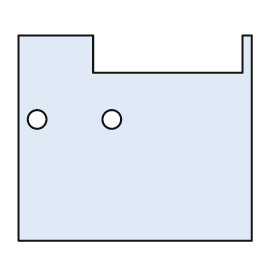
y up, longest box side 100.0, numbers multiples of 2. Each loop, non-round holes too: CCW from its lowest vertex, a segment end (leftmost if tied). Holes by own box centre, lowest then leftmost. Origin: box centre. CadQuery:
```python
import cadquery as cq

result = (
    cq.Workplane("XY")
    .moveTo(-50.0, -44.0)
    .lineTo(50.0, -44.0)
    .lineTo(50.0, 44.0)
    .lineTo(46.0, 44.0)
    .lineTo(46.0, 28.0)
    .lineTo(-18.0, 28.0)
    .lineTo(-18.0, 44.0)
    .lineTo(-50.0, 44.0)
    .close()
    .moveTo(-42.0, 8.0)
    .circle(4.0)
    .moveTo(-10.0, 8.0)
    .circle(4.0)
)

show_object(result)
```